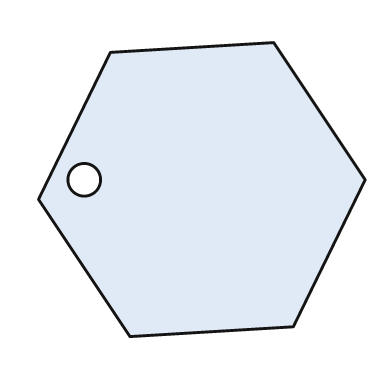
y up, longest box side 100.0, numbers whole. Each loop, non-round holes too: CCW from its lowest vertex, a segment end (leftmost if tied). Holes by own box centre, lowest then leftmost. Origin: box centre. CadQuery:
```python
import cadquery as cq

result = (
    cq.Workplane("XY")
    .moveTo(-22.0, -45.0)
    .lineTo(28.0, -42.0)
    .lineTo(50.0, 3.0)
    .lineTo(22.0, 45.0)
    .lineTo(-28.0, 42.0)
    .lineTo(-50.0, -3.0)
    .close()
    .moveTo(-36.0, 3.0)
    .circle(5.0)
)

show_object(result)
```